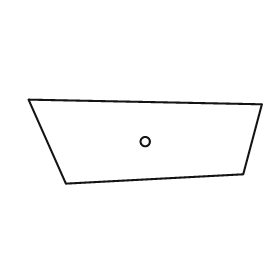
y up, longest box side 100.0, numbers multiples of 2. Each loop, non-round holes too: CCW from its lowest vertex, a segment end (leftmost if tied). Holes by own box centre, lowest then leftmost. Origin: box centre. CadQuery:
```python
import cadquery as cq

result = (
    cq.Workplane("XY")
    .moveTo(-34.0, -18.0)
    .lineTo(42.0, -14.0)
    .lineTo(50.0, 16.0)
    .lineTo(-50.0, 18.0)
    .close()
    .moveTo(0.0, 0.0)
    .circle(2.0)
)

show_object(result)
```